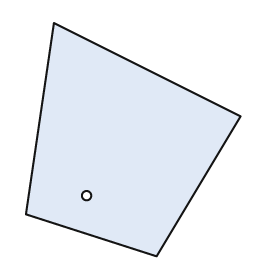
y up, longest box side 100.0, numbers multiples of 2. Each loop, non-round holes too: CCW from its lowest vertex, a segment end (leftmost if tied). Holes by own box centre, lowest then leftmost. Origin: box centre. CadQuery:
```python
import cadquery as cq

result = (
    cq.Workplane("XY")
    .moveTo(10.0, -50.0)
    .lineTo(46.0, 10.0)
    .lineTo(-34.0, 50.0)
    .lineTo(-46.0, -32.0)
    .close()
    .moveTo(-20.0, -24.0)
    .circle(2.0)
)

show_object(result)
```